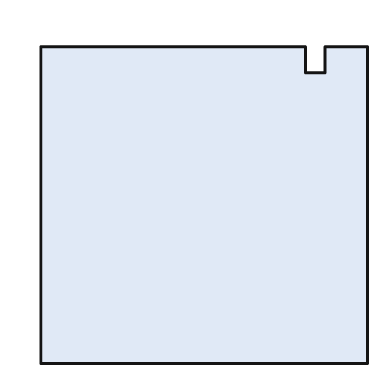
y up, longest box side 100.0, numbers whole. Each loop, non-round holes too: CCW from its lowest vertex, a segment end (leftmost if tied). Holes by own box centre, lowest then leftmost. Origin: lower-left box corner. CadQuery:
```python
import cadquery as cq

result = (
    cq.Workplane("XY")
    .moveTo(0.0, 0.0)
    .lineTo(100.0, 0.0)
    .lineTo(100.0, 97.0)
    .lineTo(87.0, 97.0)
    .lineTo(87.0, 89.0)
    .lineTo(81.0, 89.0)
    .lineTo(81.0, 97.0)
    .lineTo(0.0, 97.0)
    .close()
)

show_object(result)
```